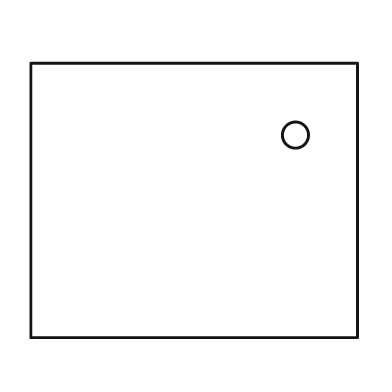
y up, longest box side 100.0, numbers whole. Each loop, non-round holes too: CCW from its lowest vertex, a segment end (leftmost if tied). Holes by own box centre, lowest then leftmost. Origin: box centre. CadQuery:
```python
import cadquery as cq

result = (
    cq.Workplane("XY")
    .moveTo(-50.0, -42.0)
    .lineTo(50.0, -42.0)
    .lineTo(50.0, 42.0)
    .lineTo(-50.0, 42.0)
    .close()
    .moveTo(31.0, 20.0)
    .circle(4.0)
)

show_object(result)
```